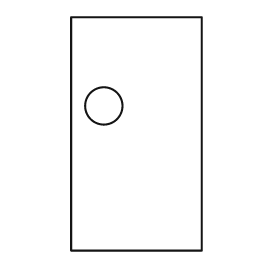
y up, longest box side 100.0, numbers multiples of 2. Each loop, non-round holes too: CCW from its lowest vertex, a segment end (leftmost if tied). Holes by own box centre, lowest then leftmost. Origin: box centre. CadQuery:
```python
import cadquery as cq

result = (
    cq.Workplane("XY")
    .moveTo(-28.0, -50.0)
    .lineTo(28.0, -50.0)
    .lineTo(28.0, 50.0)
    .lineTo(-28.0, 50.0)
    .close()
    .moveTo(-14.0, 12.0)
    .circle(8.0)
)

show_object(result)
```